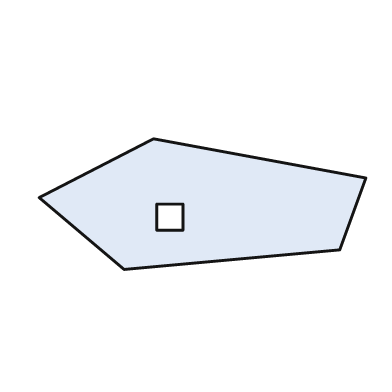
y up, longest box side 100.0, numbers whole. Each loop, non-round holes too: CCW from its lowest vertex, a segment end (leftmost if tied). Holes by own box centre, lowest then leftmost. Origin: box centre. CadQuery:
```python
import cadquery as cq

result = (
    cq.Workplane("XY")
    .moveTo(-24.0, -20.0)
    .lineTo(42.0, -14.0)
    .lineTo(50.0, 8.0)
    .lineTo(-15.0, 20.0)
    .lineTo(-50.0, 2.0)
    .close()
    .moveTo(-14.0, -8.0)
    .lineTo(-6.0, -8.0)
    .lineTo(-6.0, 0.0)
    .lineTo(-14.0, 0.0)
    .close()
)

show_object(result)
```